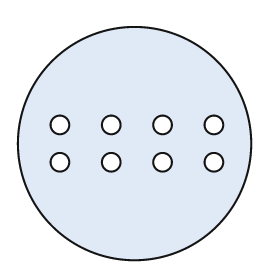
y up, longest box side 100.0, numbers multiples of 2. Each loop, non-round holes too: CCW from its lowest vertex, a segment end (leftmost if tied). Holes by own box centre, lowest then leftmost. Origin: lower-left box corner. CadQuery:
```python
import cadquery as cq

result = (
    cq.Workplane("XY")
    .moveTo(50.0, 50.0)
    .circle(50.0)
    .moveTo(18.0, 42.0)
    .circle(4.0)
    .moveTo(40.0, 42.0)
    .circle(4.0)
    .moveTo(62.0, 42.0)
    .circle(4.0)
    .moveTo(84.0, 42.0)
    .circle(4.0)
    .moveTo(18.0, 58.0)
    .circle(4.0)
    .moveTo(40.0, 58.0)
    .circle(4.0)
    .moveTo(62.0, 58.0)
    .circle(4.0)
    .moveTo(84.0, 58.0)
    .circle(4.0)
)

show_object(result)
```